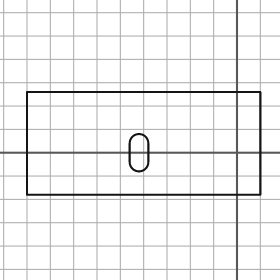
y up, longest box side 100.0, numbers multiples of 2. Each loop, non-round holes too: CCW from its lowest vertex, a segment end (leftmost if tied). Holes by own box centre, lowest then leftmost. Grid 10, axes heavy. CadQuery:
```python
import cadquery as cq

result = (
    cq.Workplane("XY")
    .moveTo(-90.0, -18.0)
    .lineTo(10.0, -18.0)
    .lineTo(10.0, 26.0)
    .lineTo(-90.0, 26.0)
    .close()
    .moveTo(-46.0, -4.0)
    .threePointArc((-42.0, -8.0), (-38.0, -4.0))
    .lineTo(-38.0, 4.0)
    .threePointArc((-42.0, 8.0), (-46.0, 4.0))
    .close()
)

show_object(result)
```